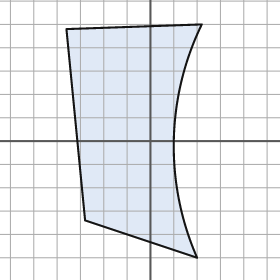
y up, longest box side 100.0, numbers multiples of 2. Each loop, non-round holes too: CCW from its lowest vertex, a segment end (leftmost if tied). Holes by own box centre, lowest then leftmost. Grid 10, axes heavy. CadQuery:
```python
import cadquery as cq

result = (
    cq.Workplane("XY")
    .moveTo(20.0, -50.0)
    .threePointArc((10.0, 0.0), (22.0, 50.0))
    .lineTo(-36.0, 48.0)
    .lineTo(-28.0, -34.0)
    .close()
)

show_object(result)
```